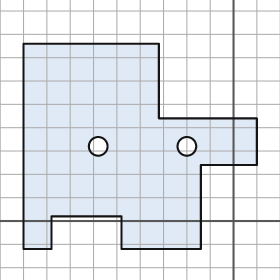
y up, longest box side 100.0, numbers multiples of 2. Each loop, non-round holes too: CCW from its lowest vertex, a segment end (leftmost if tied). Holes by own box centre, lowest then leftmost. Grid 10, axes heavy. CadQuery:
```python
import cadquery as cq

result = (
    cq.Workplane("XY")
    .moveTo(-90.0, -12.0)
    .lineTo(-78.0, -12.0)
    .lineTo(-78.0, 2.0)
    .lineTo(-48.0, 2.0)
    .lineTo(-48.0, -12.0)
    .lineTo(-14.0, -12.0)
    .lineTo(-14.0, 24.0)
    .lineTo(10.0, 24.0)
    .lineTo(10.0, 44.0)
    .lineTo(-32.0, 44.0)
    .lineTo(-32.0, 76.0)
    .lineTo(-90.0, 76.0)
    .close()
    .moveTo(-58.0, 32.0)
    .circle(4.0)
    .moveTo(-20.0, 32.0)
    .circle(4.0)
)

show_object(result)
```